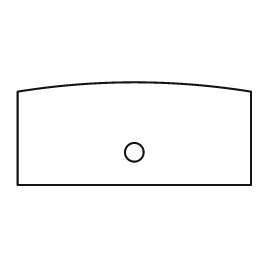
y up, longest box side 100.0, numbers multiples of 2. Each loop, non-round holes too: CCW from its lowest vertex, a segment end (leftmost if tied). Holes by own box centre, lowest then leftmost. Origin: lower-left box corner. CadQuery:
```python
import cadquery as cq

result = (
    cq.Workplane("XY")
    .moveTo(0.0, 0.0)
    .lineTo(100.0, 0.0)
    .lineTo(100.0, 40.0)
    .threePointArc((50.0, 44.0), (0.0, 40.0))
    .close()
    .moveTo(50.0, 14.0)
    .circle(4.0)
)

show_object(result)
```